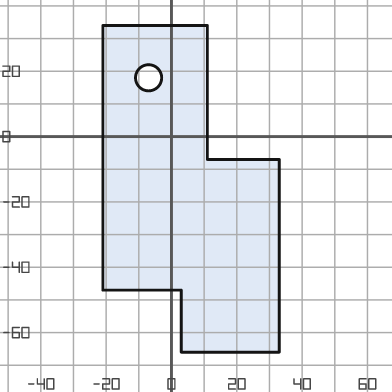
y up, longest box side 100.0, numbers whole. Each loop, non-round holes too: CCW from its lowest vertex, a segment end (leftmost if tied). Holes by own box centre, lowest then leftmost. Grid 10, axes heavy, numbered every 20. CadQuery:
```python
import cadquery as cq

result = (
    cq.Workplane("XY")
    .moveTo(3.0, -66.0)
    .lineTo(33.0, -66.0)
    .lineTo(33.0, -7.0)
    .lineTo(11.0, -7.0)
    .lineTo(11.0, 34.0)
    .lineTo(-21.0, 34.0)
    .lineTo(-21.0, -47.0)
    .lineTo(3.0, -47.0)
    .close()
    .moveTo(-7.0, 18.0)
    .circle(4.0)
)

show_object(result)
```